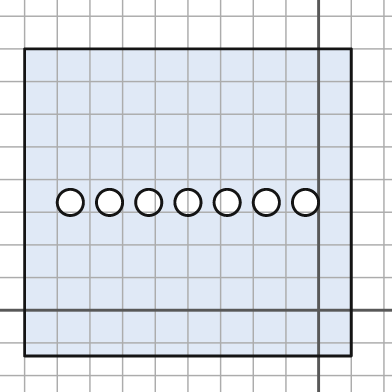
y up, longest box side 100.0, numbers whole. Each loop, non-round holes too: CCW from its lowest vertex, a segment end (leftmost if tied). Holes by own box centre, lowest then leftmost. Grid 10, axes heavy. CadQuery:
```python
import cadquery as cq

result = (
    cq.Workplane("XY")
    .moveTo(-90.0, -14.0)
    .lineTo(10.0, -14.0)
    .lineTo(10.0, 80.0)
    .lineTo(-90.0, 80.0)
    .close()
    .moveTo(-76.0, 33.0)
    .circle(4.0)
    .moveTo(-64.0, 33.0)
    .circle(4.0)
    .moveTo(-52.0, 33.0)
    .circle(4.0)
    .moveTo(-40.0, 33.0)
    .circle(4.0)
    .moveTo(-28.0, 33.0)
    .circle(4.0)
    .moveTo(-16.0, 33.0)
    .circle(4.0)
    .moveTo(-4.0, 33.0)
    .circle(4.0)
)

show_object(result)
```